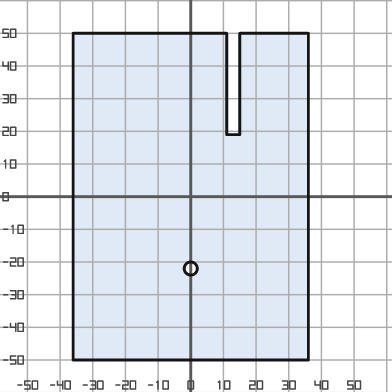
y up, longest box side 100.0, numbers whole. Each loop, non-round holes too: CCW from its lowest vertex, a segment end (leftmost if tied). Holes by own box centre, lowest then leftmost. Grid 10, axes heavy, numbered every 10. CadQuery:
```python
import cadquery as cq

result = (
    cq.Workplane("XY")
    .moveTo(-36.0, -50.0)
    .lineTo(36.0, -50.0)
    .lineTo(36.0, 50.0)
    .lineTo(15.0, 50.0)
    .lineTo(15.0, 19.0)
    .lineTo(11.0, 19.0)
    .lineTo(11.0, 50.0)
    .lineTo(-36.0, 50.0)
    .close()
    .moveTo(0.0, -22.0)
    .circle(2.0)
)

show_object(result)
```